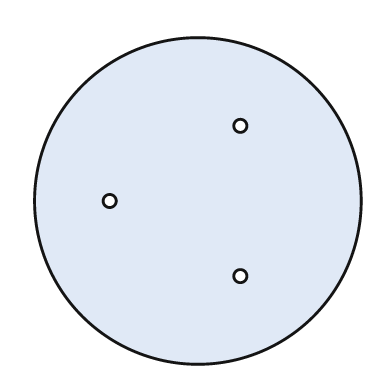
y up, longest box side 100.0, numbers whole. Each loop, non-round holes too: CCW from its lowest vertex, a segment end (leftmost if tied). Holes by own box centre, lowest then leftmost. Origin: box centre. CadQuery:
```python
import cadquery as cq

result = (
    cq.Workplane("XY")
    .moveTo(0.0, 0.0)
    .circle(50.0)
    .moveTo(13.0, -23.0)
    .circle(2.0)
    .moveTo(-27.0, 0.0)
    .circle(2.0)
    .moveTo(13.0, 23.0)
    .circle(2.0)
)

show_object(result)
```